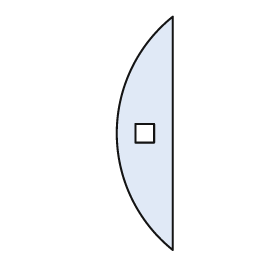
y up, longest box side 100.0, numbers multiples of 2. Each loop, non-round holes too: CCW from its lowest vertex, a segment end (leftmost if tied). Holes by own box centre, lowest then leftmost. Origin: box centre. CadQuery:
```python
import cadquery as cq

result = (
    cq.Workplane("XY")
    .moveTo(12.0, -50.0)
    .lineTo(12.0, 50.0)
    .threePointArc((-12.0, 0.0), (12.0, -50.0))
    .close()
    .moveTo(-4.0, -4.0)
    .lineTo(4.0, -4.0)
    .lineTo(4.0, 4.0)
    .lineTo(-4.0, 4.0)
    .close()
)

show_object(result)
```